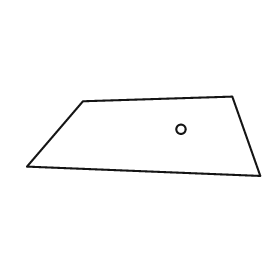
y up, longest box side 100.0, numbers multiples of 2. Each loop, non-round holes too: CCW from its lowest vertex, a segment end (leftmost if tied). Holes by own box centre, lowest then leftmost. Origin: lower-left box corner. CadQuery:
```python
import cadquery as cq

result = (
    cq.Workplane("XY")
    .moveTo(100.0, 0.0)
    .lineTo(88.0, 34.0)
    .lineTo(24.0, 32.0)
    .lineTo(0.0, 4.0)
    .close()
    .moveTo(66.0, 20.0)
    .circle(2.0)
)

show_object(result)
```